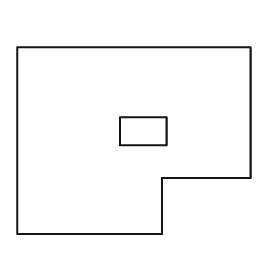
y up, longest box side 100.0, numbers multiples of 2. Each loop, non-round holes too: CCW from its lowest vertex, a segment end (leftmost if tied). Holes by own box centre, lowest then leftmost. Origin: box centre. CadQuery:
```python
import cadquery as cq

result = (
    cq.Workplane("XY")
    .moveTo(-50.0, -40.0)
    .lineTo(12.0, -40.0)
    .lineTo(12.0, -16.0)
    .lineTo(50.0, -16.0)
    .lineTo(50.0, 40.0)
    .lineTo(-50.0, 40.0)
    .close()
    .moveTo(-6.0, -2.0)
    .lineTo(14.0, -2.0)
    .lineTo(14.0, 10.0)
    .lineTo(-6.0, 10.0)
    .close()
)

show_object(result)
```